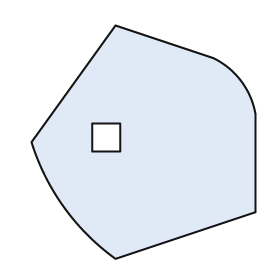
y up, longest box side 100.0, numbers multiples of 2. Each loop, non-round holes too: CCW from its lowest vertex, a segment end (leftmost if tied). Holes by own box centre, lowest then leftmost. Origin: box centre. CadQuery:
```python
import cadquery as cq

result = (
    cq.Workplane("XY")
    .moveTo(-12.0, -50.0)
    .lineTo(48.0, -30.0)
    .lineTo(48.0, 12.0)
    .threePointArc((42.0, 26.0), (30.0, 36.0))
    .lineTo(-12.0, 50.0)
    .lineTo(-48.0, 0.0)
    .threePointArc((-34.0, -28.0), (-12.0, -50.0))
    .close()
    .moveTo(-22.0, -4.0)
    .lineTo(-10.0, -4.0)
    .lineTo(-10.0, 8.0)
    .lineTo(-22.0, 8.0)
    .close()
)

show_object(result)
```